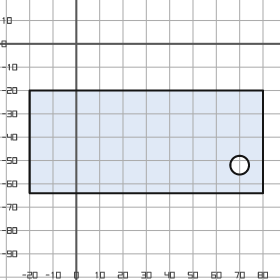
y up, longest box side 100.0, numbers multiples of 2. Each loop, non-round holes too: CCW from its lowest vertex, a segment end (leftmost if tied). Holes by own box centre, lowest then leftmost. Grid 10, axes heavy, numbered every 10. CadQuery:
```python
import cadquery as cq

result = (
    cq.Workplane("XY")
    .moveTo(-20.0, -64.0)
    .lineTo(80.0, -64.0)
    .lineTo(80.0, -20.0)
    .lineTo(-20.0, -20.0)
    .close()
    .moveTo(70.0, -52.0)
    .circle(4.0)
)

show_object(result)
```